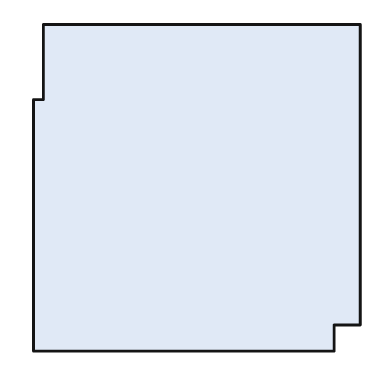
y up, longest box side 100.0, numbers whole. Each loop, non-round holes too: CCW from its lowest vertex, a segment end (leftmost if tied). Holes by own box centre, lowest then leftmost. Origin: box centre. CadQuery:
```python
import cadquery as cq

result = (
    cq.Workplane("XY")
    .moveTo(-50.0, -50.0)
    .lineTo(42.0, -50.0)
    .lineTo(42.0, -42.0)
    .lineTo(50.0, -42.0)
    .lineTo(50.0, 50.0)
    .lineTo(-47.0, 50.0)
    .lineTo(-47.0, 27.0)
    .lineTo(-50.0, 27.0)
    .close()
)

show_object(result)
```